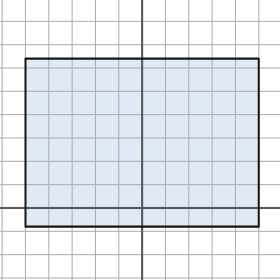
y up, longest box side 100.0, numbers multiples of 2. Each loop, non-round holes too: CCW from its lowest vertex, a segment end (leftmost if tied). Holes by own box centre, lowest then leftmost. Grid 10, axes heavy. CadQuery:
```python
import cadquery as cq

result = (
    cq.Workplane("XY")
    .moveTo(-50.0, -8.0)
    .lineTo(50.0, -8.0)
    .lineTo(50.0, 64.0)
    .lineTo(-50.0, 64.0)
    .close()
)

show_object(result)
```